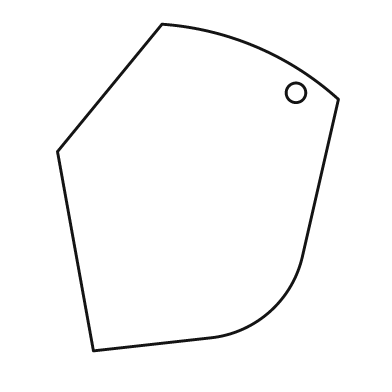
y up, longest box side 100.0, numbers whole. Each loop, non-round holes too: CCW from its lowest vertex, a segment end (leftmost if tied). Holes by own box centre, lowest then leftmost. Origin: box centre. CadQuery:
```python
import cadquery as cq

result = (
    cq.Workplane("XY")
    .moveTo(-32.0, -50.0)
    .lineTo(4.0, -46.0)
    .threePointArc((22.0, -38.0), (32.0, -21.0))
    .lineTo(43.0, 27.0)
    .threePointArc((18.0, 43.0), (-11.0, 50.0))
    .lineTo(-43.0, 11.0)
    .close()
    .moveTo(30.0, 29.0)
    .circle(3.0)
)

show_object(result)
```